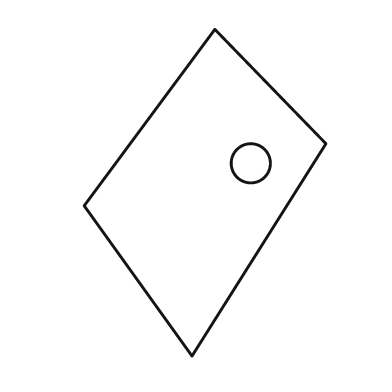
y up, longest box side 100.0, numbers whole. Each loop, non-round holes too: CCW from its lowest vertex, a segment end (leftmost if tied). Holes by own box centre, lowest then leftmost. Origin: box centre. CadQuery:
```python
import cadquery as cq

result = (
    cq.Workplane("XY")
    .moveTo(-4.0, -50.0)
    .lineTo(37.0, 15.0)
    .lineTo(3.0, 50.0)
    .lineTo(-37.0, -4.0)
    .close()
    .moveTo(14.0, 9.0)
    .circle(6.0)
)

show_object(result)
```